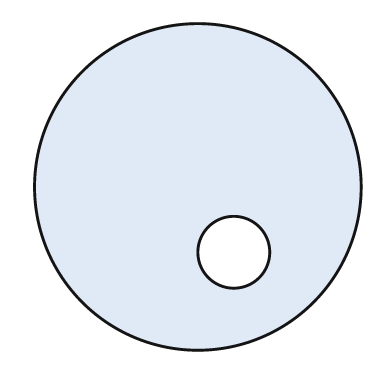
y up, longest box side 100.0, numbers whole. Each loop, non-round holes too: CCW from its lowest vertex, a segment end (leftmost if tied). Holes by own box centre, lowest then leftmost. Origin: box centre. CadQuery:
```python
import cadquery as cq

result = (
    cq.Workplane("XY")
    .moveTo(0.0, 0.0)
    .circle(50.0)
    .moveTo(11.0, -20.0)
    .circle(11.0)
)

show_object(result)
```